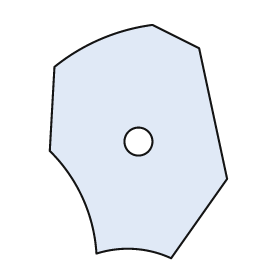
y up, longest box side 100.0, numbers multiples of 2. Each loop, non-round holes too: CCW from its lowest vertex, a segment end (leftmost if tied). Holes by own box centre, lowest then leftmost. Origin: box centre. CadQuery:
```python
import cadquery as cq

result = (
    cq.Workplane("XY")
    .moveTo(14.0, -50.0)
    .lineTo(38.0, -16.0)
    .lineTo(26.0, 40.0)
    .lineTo(6.0, 50.0)
    .threePointArc((-16.0, 44.0), (-36.0, 32.0))
    .lineTo(-38.0, -4.0)
    .threePointArc((-24.0, -24.0), (-18.0, -48.0))
    .threePointArc((-2.0, -46.0), (14.0, -50.0))
    .close()
    .moveTo(0.0, 0.0)
    .circle(6.0)
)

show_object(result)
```